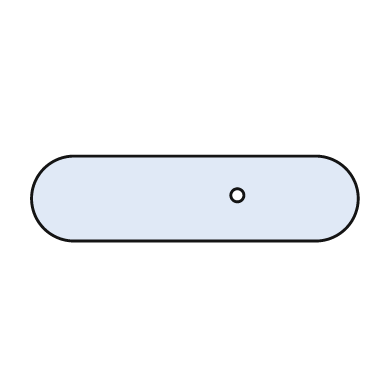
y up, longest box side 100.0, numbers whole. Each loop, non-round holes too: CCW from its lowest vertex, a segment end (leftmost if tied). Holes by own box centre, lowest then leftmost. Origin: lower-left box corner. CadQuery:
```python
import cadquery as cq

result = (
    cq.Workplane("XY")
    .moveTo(13.0, 0.0)
    .lineTo(87.0, 0.0)
    .threePointArc((100.0, 13.0), (87.0, 26.0))
    .lineTo(13.0, 26.0)
    .threePointArc((0.0, 13.0), (13.0, 0.0))
    .close()
    .moveTo(63.0, 14.0)
    .circle(2.0)
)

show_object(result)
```